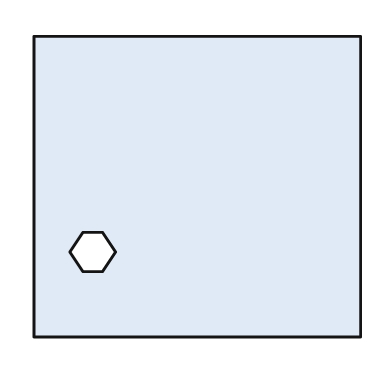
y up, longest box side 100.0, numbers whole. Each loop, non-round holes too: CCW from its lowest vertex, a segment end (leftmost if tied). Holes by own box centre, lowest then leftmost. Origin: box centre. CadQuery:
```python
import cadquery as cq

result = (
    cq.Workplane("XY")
    .moveTo(-50.0, -46.0)
    .lineTo(50.0, -46.0)
    .lineTo(50.0, 46.0)
    .lineTo(-50.0, 46.0)
    .close()
    .moveTo(-35.0, -26.0)
    .lineTo(-29.0, -26.0)
    .lineTo(-25.0, -20.0)
    .lineTo(-29.0, -14.0)
    .lineTo(-35.0, -14.0)
    .lineTo(-39.0, -20.0)
    .close()
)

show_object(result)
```